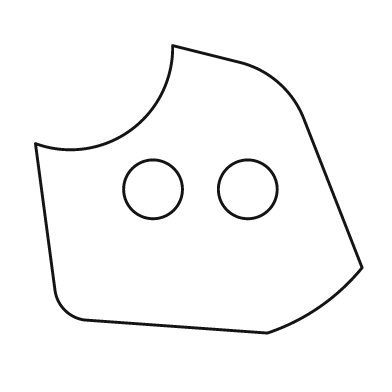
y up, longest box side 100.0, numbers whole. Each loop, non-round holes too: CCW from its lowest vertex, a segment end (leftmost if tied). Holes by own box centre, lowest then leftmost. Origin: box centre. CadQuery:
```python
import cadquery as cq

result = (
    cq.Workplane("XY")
    .moveTo(21.0, -44.0)
    .threePointArc((37.0, -36.0), (50.0, -24.0))
    .lineTo(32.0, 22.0)
    .threePointArc((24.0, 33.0), (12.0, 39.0))
    .lineTo(-8.0, 44.0)
    .threePointArc((-21.0, 18.0), (-50.0, 14.0))
    .lineTo(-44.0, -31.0)
    .threePointArc((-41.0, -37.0), (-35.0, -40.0))
    .close()
    .moveTo(-14.0, 0.0)
    .circle(9.0)
    .moveTo(15.0, 0.0)
    .circle(9.0)
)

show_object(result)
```